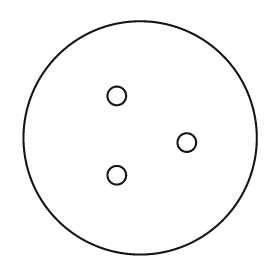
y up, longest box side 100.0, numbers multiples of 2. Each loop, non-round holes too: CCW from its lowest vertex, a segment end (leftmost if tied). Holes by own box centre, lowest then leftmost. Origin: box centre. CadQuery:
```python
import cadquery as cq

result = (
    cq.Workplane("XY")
    .moveTo(0.0, 0.0)
    .circle(50.0)
    .moveTo(-10.0, -16.0)
    .circle(4.0)
    .moveTo(20.0, -2.0)
    .circle(4.0)
    .moveTo(-10.0, 18.0)
    .circle(4.0)
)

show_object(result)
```